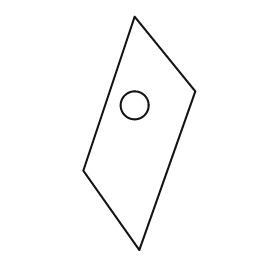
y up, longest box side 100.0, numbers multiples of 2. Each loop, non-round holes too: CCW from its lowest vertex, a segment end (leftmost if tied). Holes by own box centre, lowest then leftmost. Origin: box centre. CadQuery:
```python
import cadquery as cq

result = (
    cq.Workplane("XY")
    .moveTo(0.0, -50.0)
    .lineTo(24.0, 18.0)
    .lineTo(-2.0, 50.0)
    .lineTo(-24.0, -16.0)
    .close()
    .moveTo(-2.0, 12.0)
    .circle(6.0)
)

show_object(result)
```